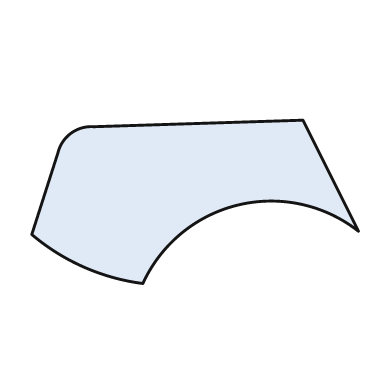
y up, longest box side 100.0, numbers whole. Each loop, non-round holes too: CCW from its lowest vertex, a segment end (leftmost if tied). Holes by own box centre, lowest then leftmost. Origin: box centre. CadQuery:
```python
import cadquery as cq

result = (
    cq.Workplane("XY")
    .moveTo(-16.0, -25.0)
    .threePointArc((13.0, -1.0), (50.0, -9.0))
    .lineTo(33.0, 25.0)
    .lineTo(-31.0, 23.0)
    .threePointArc((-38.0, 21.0), (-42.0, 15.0))
    .lineTo(-50.0, -10.0)
    .threePointArc((-34.0, -20.0), (-16.0, -25.0))
    .close()
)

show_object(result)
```